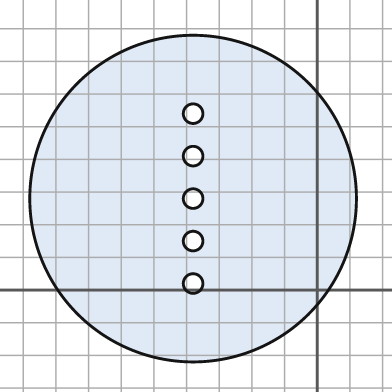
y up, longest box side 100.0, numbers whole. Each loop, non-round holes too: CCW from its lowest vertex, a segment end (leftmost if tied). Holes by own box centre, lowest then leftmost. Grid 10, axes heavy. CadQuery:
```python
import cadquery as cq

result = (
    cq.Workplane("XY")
    .moveTo(-38.0, 28.0)
    .circle(50.0)
    .moveTo(-38.0, 2.0)
    .circle(3.0)
    .moveTo(-38.0, 15.0)
    .circle(3.0)
    .moveTo(-38.0, 28.0)
    .circle(3.0)
    .moveTo(-38.0, 41.0)
    .circle(3.0)
    .moveTo(-38.0, 54.0)
    .circle(3.0)
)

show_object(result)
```